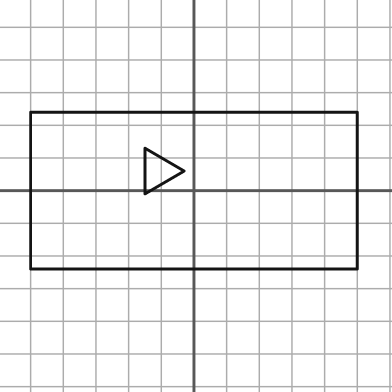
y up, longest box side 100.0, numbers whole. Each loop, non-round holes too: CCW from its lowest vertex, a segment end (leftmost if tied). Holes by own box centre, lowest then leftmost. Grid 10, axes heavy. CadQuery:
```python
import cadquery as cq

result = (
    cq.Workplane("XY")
    .moveTo(-50.0, -24.0)
    .lineTo(50.0, -24.0)
    .lineTo(50.0, 24.0)
    .lineTo(-50.0, 24.0)
    .close()
    .moveTo(-15.0, -1.0)
    .lineTo(-3.0, 6.0)
    .lineTo(-15.0, 13.0)
    .close()
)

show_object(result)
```